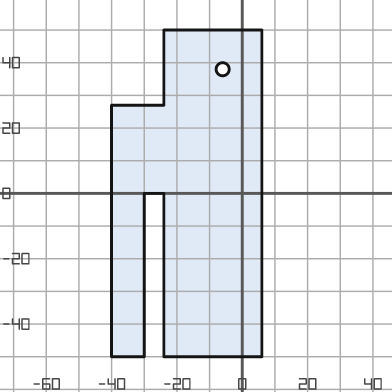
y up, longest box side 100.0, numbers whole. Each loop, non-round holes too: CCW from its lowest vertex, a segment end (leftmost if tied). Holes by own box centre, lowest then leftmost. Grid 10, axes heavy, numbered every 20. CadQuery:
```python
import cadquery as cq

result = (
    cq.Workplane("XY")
    .moveTo(-40.0, -50.0)
    .lineTo(-30.0, -50.0)
    .lineTo(-30.0, 0.0)
    .lineTo(-24.0, 0.0)
    .lineTo(-24.0, -50.0)
    .lineTo(6.0, -50.0)
    .lineTo(6.0, 50.0)
    .lineTo(-24.0, 50.0)
    .lineTo(-24.0, 27.0)
    .lineTo(-40.0, 27.0)
    .close()
    .moveTo(-6.0, 38.0)
    .circle(2.0)
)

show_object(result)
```